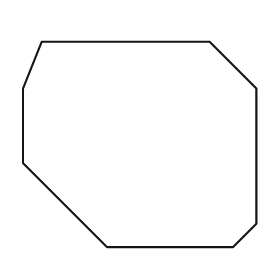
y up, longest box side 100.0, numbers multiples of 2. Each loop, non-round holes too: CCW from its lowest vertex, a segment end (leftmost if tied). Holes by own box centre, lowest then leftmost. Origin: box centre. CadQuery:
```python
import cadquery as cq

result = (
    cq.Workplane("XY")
    .moveTo(-14.0, -44.0)
    .lineTo(40.0, -44.0)
    .lineTo(50.0, -34.0)
    .lineTo(50.0, 24.0)
    .lineTo(30.0, 44.0)
    .lineTo(-42.0, 44.0)
    .lineTo(-50.0, 24.0)
    .lineTo(-50.0, -8.0)
    .close()
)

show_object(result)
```